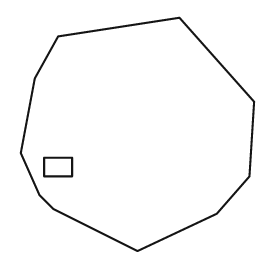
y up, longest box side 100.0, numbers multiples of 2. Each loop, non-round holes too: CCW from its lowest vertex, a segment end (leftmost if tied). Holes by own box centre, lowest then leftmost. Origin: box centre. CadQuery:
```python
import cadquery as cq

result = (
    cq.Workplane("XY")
    .moveTo(0.0, -50.0)
    .lineTo(34.0, -34.0)
    .lineTo(48.0, -18.0)
    .lineTo(50.0, 14.0)
    .lineTo(18.0, 50.0)
    .lineTo(-34.0, 42.0)
    .lineTo(-44.0, 24.0)
    .lineTo(-50.0, -8.0)
    .lineTo(-42.0, -26.0)
    .lineTo(-36.0, -32.0)
    .close()
    .moveTo(-40.0, -18.0)
    .lineTo(-28.0, -18.0)
    .lineTo(-28.0, -10.0)
    .lineTo(-40.0, -10.0)
    .close()
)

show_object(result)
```